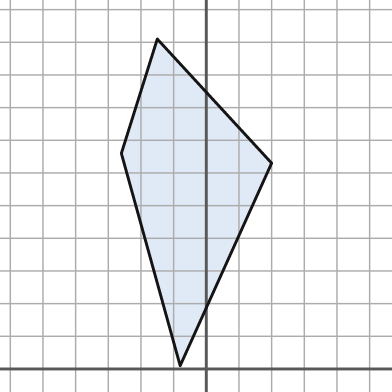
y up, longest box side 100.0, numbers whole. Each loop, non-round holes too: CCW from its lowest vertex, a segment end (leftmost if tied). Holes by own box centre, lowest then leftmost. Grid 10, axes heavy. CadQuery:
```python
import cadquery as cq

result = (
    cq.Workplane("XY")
    .moveTo(-8.0, 1.0)
    .lineTo(20.0, 63.0)
    .lineTo(-15.0, 101.0)
    .lineTo(-26.0, 66.0)
    .close()
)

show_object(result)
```